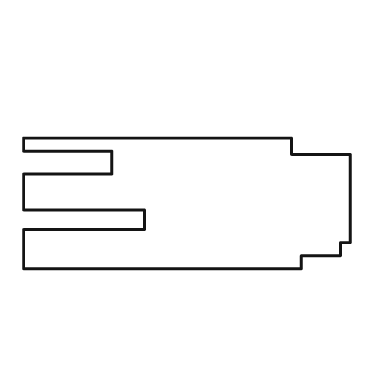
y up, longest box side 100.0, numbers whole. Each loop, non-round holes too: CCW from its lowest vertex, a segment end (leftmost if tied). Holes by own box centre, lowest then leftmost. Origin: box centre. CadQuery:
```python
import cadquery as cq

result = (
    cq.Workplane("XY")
    .moveTo(-50.0, -20.0)
    .lineTo(35.0, -20.0)
    .lineTo(35.0, -16.0)
    .lineTo(47.0, -16.0)
    .lineTo(47.0, -12.0)
    .lineTo(50.0, -12.0)
    .lineTo(50.0, 15.0)
    .lineTo(32.0, 15.0)
    .lineTo(32.0, 20.0)
    .lineTo(-50.0, 20.0)
    .lineTo(-50.0, 16.0)
    .lineTo(-23.0, 16.0)
    .lineTo(-23.0, 9.0)
    .lineTo(-50.0, 9.0)
    .lineTo(-50.0, -2.0)
    .lineTo(-13.0, -2.0)
    .lineTo(-13.0, -8.0)
    .lineTo(-50.0, -8.0)
    .close()
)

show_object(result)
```